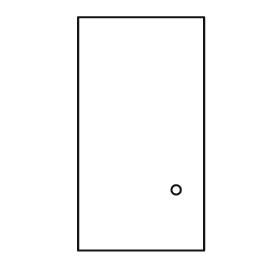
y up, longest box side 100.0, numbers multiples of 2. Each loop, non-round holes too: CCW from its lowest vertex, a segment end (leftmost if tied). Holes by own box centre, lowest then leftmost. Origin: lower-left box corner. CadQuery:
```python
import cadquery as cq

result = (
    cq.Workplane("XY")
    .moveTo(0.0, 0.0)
    .lineTo(54.0, 0.0)
    .lineTo(54.0, 100.0)
    .lineTo(0.0, 100.0)
    .close()
    .moveTo(42.0, 26.0)
    .circle(2.0)
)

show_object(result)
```